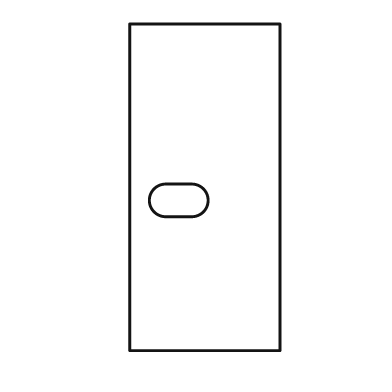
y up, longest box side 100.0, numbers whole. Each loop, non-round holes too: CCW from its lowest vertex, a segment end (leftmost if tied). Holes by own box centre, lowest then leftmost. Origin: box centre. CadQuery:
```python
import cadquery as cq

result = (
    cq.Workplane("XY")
    .moveTo(-23.0, -50.0)
    .lineTo(23.0, -50.0)
    .lineTo(23.0, 50.0)
    .lineTo(-23.0, 50.0)
    .close()
    .moveTo(-12.0, -9.0)
    .lineTo(-4.0, -9.0)
    .threePointArc((1.0, -4.0), (-4.0, 1.0))
    .lineTo(-12.0, 1.0)
    .threePointArc((-17.0, -4.0), (-12.0, -9.0))
    .close()
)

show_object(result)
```